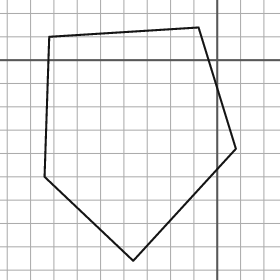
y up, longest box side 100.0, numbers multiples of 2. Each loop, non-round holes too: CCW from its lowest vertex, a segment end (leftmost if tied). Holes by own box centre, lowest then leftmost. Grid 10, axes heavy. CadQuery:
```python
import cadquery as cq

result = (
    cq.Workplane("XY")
    .moveTo(-36.0, -86.0)
    .lineTo(8.0, -38.0)
    .lineTo(-8.0, 14.0)
    .lineTo(-72.0, 10.0)
    .lineTo(-74.0, -50.0)
    .close()
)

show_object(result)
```